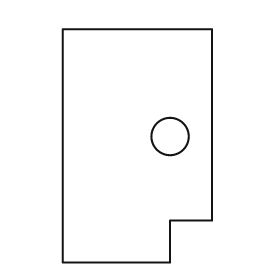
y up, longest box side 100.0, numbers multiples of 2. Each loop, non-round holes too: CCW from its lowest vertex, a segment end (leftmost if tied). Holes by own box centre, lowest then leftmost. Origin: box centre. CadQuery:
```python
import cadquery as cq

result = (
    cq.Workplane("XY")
    .moveTo(-32.0, -50.0)
    .lineTo(14.0, -50.0)
    .lineTo(14.0, -32.0)
    .lineTo(32.0, -32.0)
    .lineTo(32.0, 50.0)
    .lineTo(-32.0, 50.0)
    .close()
    .moveTo(14.0, 4.0)
    .circle(8.0)
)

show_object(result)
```